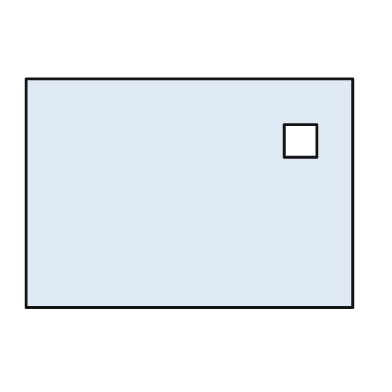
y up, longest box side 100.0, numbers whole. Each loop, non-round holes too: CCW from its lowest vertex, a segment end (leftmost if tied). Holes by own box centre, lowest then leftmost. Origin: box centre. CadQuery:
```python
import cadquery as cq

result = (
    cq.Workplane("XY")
    .moveTo(-50.0, -35.0)
    .lineTo(50.0, -35.0)
    .lineTo(50.0, 35.0)
    .lineTo(-50.0, 35.0)
    .close()
    .moveTo(29.0, 11.0)
    .lineTo(39.0, 11.0)
    .lineTo(39.0, 21.0)
    .lineTo(29.0, 21.0)
    .close()
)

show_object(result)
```